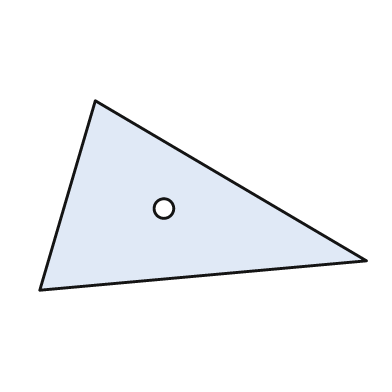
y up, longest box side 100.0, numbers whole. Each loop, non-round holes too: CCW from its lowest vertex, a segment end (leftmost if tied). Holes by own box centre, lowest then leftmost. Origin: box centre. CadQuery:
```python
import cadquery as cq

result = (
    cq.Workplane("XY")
    .moveTo(-50.0, -29.0)
    .lineTo(50.0, -20.0)
    .lineTo(-33.0, 29.0)
    .close()
    .moveTo(-12.0, -4.0)
    .circle(3.0)
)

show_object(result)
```